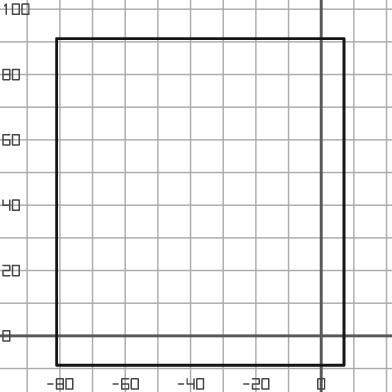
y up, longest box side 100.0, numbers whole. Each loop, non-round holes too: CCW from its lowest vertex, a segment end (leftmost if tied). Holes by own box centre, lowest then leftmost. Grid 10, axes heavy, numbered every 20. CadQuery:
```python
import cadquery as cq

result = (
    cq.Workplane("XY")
    .moveTo(-81.0, -9.0)
    .lineTo(7.0, -9.0)
    .lineTo(7.0, 91.0)
    .lineTo(-81.0, 91.0)
    .close()
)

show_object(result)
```